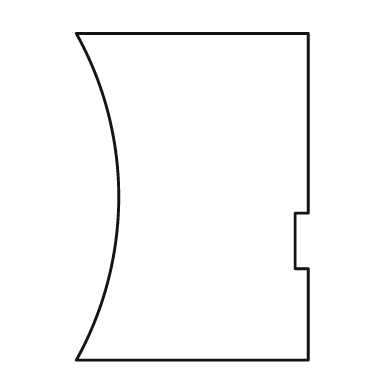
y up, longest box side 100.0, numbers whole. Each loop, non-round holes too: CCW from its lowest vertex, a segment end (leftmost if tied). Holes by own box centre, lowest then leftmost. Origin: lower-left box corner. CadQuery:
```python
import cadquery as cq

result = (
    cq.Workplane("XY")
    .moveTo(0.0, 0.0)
    .lineTo(71.0, 0.0)
    .lineTo(71.0, 28.0)
    .lineTo(67.0, 28.0)
    .lineTo(67.0, 45.0)
    .lineTo(71.0, 45.0)
    .lineTo(71.0, 100.0)
    .lineTo(0.0, 100.0)
    .threePointArc((13.0, 50.0), (0.0, 0.0))
    .close()
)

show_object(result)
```